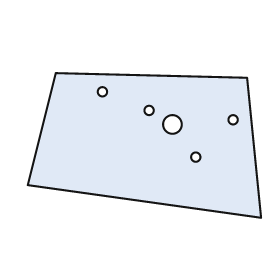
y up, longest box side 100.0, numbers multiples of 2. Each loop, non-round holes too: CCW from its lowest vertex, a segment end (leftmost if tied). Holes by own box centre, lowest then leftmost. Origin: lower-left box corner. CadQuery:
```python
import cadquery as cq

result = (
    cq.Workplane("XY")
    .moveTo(100.0, 0.0)
    .lineTo(94.0, 60.0)
    .lineTo(12.0, 62.0)
    .lineTo(0.0, 14.0)
    .close()
    .moveTo(72.0, 26.0)
    .circle(2.0)
    .moveTo(62.0, 40.0)
    .circle(4.0)
    .moveTo(88.0, 42.0)
    .circle(2.0)
    .moveTo(52.0, 46.0)
    .circle(2.0)
    .moveTo(32.0, 54.0)
    .circle(2.0)
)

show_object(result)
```